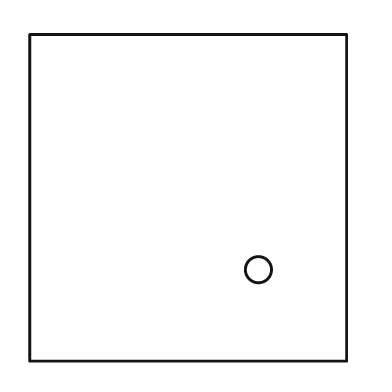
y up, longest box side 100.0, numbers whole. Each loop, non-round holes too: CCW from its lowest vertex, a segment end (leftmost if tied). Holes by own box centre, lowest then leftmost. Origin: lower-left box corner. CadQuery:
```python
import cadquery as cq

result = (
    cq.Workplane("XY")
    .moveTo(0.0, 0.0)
    .lineTo(97.0, 0.0)
    .lineTo(97.0, 100.0)
    .lineTo(0.0, 100.0)
    .close()
    .moveTo(70.0, 28.0)
    .circle(4.0)
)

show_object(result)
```